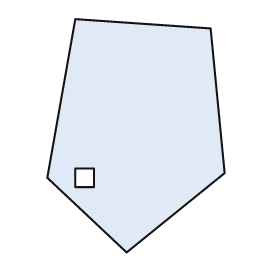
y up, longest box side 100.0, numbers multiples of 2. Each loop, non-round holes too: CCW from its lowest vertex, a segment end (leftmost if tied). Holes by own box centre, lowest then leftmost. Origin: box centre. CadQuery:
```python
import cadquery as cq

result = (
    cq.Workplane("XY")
    .moveTo(-4.0, -50.0)
    .lineTo(38.0, -16.0)
    .lineTo(32.0, 46.0)
    .lineTo(-26.0, 50.0)
    .lineTo(-38.0, -18.0)
    .close()
    .moveTo(-26.0, -22.0)
    .lineTo(-18.0, -22.0)
    .lineTo(-18.0, -14.0)
    .lineTo(-26.0, -14.0)
    .close()
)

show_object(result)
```